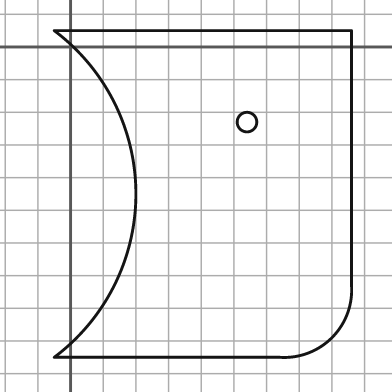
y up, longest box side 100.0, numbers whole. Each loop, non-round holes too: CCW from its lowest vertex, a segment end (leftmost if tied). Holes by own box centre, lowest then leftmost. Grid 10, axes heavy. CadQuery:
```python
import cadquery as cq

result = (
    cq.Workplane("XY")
    .moveTo(-5.0, -95.0)
    .lineTo(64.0, -95.0)
    .threePointArc((80.0, -89.0), (86.0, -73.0))
    .lineTo(86.0, 5.0)
    .lineTo(-5.0, 5.0)
    .threePointArc((20.0, -45.0), (-5.0, -95.0))
    .close()
    .moveTo(54.0, -23.0)
    .circle(3.0)
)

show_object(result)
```